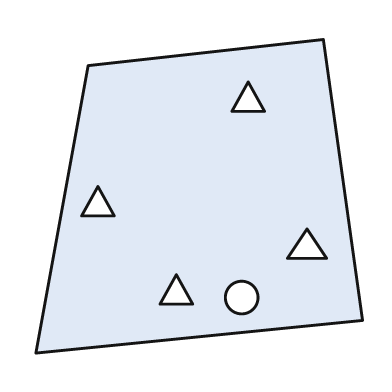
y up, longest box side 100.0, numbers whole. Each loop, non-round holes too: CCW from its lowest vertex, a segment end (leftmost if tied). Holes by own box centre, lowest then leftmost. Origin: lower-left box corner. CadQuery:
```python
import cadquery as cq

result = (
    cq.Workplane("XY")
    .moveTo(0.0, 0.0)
    .lineTo(100.0, 10.0)
    .lineTo(88.0, 96.0)
    .lineTo(16.0, 88.0)
    .close()
    .moveTo(63.0, 17.0)
    .circle(5.0)
    .moveTo(38.0, 15.0)
    .lineTo(48.0, 15.0)
    .lineTo(43.0, 24.0)
    .close()
    .moveTo(77.0, 29.0)
    .lineTo(89.0, 29.0)
    .lineTo(83.0, 38.0)
    .close()
    .moveTo(14.0, 42.0)
    .lineTo(24.0, 42.0)
    .lineTo(19.0, 51.0)
    .close()
    .moveTo(60.0, 74.0)
    .lineTo(70.0, 74.0)
    .lineTo(65.0, 83.0)
    .close()
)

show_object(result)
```